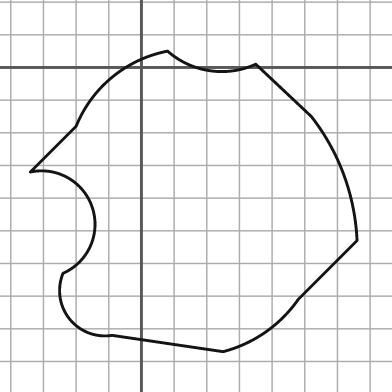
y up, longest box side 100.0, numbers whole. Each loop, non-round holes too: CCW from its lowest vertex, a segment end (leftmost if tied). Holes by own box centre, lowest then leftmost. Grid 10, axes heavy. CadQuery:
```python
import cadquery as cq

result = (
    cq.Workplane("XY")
    .moveTo(25.0, -87.0)
    .threePointArc((38.0, -81.0), (48.0, -71.0))
    .lineTo(66.0, -53.0)
    .threePointArc((62.0, -33.0), (52.0, -15.0))
    .lineTo(35.0, 1.0)
    .threePointArc((21.0, -1.0), (8.0, 5.0))
    .threePointArc((-9.0, -3.0), (-20.0, -18.0))
    .lineTo(-34.0, -32.0)
    .threePointArc((-15.0, -43.0), (-24.0, -63.0))
    .threePointArc((-22.0, -77.0), (-9.0, -82.0))
    .close()
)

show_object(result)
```